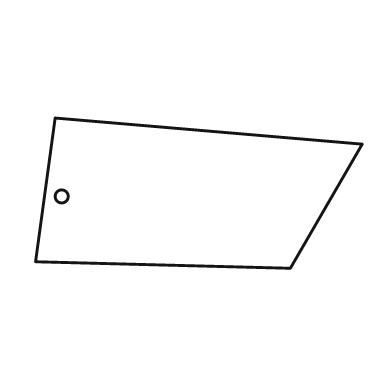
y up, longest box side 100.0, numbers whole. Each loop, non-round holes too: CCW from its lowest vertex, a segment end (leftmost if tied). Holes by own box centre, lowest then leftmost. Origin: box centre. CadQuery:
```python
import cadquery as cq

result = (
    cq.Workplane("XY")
    .moveTo(28.0, -23.0)
    .lineTo(50.0, 15.0)
    .lineTo(-44.0, 23.0)
    .lineTo(-50.0, -21.0)
    .close()
    .moveTo(-42.0, -1.0)
    .circle(2.0)
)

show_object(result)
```